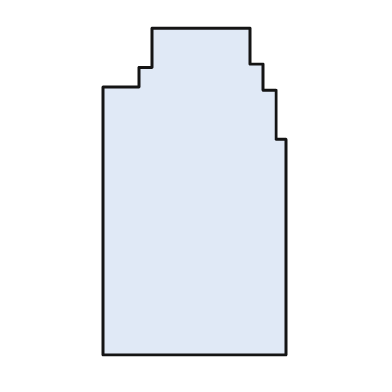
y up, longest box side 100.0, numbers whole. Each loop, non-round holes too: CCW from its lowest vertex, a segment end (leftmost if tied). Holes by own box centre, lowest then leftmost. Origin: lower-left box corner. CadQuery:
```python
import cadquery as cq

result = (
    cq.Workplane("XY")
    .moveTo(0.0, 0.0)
    .lineTo(56.0, 0.0)
    .lineTo(56.0, 66.0)
    .lineTo(53.0, 66.0)
    .lineTo(53.0, 81.0)
    .lineTo(49.0, 81.0)
    .lineTo(49.0, 89.0)
    .lineTo(45.0, 89.0)
    .lineTo(45.0, 100.0)
    .lineTo(15.0, 100.0)
    .lineTo(15.0, 88.0)
    .lineTo(11.0, 88.0)
    .lineTo(11.0, 82.0)
    .lineTo(0.0, 82.0)
    .close()
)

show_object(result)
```